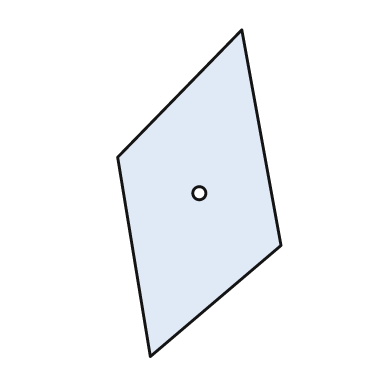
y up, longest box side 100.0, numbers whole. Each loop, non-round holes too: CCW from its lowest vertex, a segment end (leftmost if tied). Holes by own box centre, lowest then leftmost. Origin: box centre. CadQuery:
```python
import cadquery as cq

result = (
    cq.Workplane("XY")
    .moveTo(-15.0, -50.0)
    .lineTo(25.0, -16.0)
    .lineTo(13.0, 50.0)
    .lineTo(-25.0, 11.0)
    .close()
    .moveTo(0.0, 0.0)
    .circle(2.0)
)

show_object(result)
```